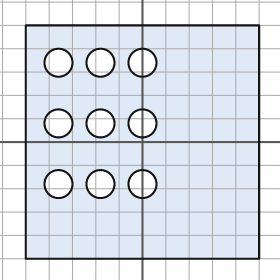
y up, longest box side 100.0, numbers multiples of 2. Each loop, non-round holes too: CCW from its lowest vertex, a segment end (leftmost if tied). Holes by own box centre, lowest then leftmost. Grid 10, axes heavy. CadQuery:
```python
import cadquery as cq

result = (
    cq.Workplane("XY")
    .moveTo(-50.0, -50.0)
    .lineTo(50.0, -50.0)
    .lineTo(50.0, 50.0)
    .lineTo(-50.0, 50.0)
    .close()
    .moveTo(-36.0, -18.0)
    .circle(6.0)
    .moveTo(-18.0, -18.0)
    .circle(6.0)
    .moveTo(0.0, -18.0)
    .circle(6.0)
    .moveTo(-36.0, 8.0)
    .circle(6.0)
    .moveTo(-18.0, 8.0)
    .circle(6.0)
    .moveTo(0.0, 8.0)
    .circle(6.0)
    .moveTo(-36.0, 34.0)
    .circle(6.0)
    .moveTo(-18.0, 34.0)
    .circle(6.0)
    .moveTo(0.0, 34.0)
    .circle(6.0)
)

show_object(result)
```